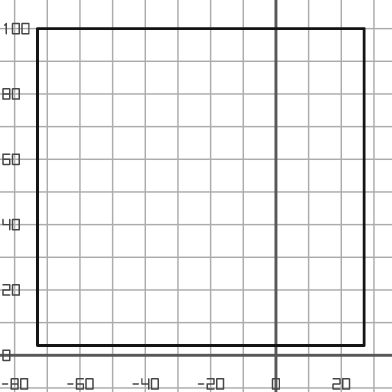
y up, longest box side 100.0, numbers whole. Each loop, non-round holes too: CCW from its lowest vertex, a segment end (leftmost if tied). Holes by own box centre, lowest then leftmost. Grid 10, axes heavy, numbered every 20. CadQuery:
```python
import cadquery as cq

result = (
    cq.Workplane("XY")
    .moveTo(-73.0, 3.0)
    .lineTo(27.0, 3.0)
    .lineTo(27.0, 100.0)
    .lineTo(-73.0, 100.0)
    .close()
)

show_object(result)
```